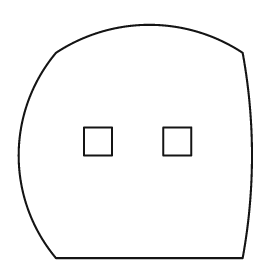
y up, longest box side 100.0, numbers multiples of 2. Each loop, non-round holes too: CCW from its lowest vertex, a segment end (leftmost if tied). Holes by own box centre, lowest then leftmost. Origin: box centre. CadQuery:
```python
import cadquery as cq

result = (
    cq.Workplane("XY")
    .moveTo(-34.0, -50.0)
    .lineTo(46.0, -50.0)
    .threePointArc((50.0, -6.0), (46.0, 38.0))
    .threePointArc((6.0, 50.0), (-34.0, 38.0))
    .threePointArc((-50.0, -6.0), (-34.0, -50.0))
    .close()
    .moveTo(-22.0, -6.0)
    .lineTo(-10.0, -6.0)
    .lineTo(-10.0, 6.0)
    .lineTo(-22.0, 6.0)
    .close()
    .moveTo(12.0, -6.0)
    .lineTo(24.0, -6.0)
    .lineTo(24.0, 6.0)
    .lineTo(12.0, 6.0)
    .close()
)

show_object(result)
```